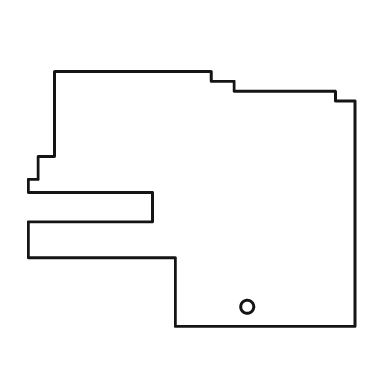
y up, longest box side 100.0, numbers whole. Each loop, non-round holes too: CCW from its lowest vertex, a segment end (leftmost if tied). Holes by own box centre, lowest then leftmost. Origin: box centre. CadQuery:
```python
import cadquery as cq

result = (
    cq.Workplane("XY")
    .moveTo(-5.0, -39.0)
    .lineTo(50.0, -39.0)
    .lineTo(50.0, 30.0)
    .lineTo(44.0, 30.0)
    .lineTo(44.0, 33.0)
    .lineTo(13.0, 33.0)
    .lineTo(13.0, 36.0)
    .lineTo(6.0, 36.0)
    .lineTo(6.0, 39.0)
    .lineTo(-42.0, 39.0)
    .lineTo(-42.0, 13.0)
    .lineTo(-47.0, 13.0)
    .lineTo(-47.0, 6.0)
    .lineTo(-50.0, 6.0)
    .lineTo(-50.0, 2.0)
    .lineTo(-12.0, 2.0)
    .lineTo(-12.0, -7.0)
    .lineTo(-50.0, -7.0)
    .lineTo(-50.0, -18.0)
    .lineTo(-5.0, -18.0)
    .close()
    .moveTo(17.0, -33.0)
    .circle(2.0)
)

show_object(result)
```